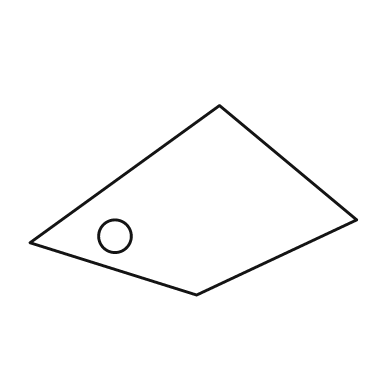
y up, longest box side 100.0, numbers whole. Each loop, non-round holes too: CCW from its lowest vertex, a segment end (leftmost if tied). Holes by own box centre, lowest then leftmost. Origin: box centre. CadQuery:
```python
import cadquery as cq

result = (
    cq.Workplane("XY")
    .moveTo(1.0, -29.0)
    .lineTo(50.0, -6.0)
    .lineTo(8.0, 29.0)
    .lineTo(-50.0, -13.0)
    .close()
    .moveTo(-24.0, -11.0)
    .circle(5.0)
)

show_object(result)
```